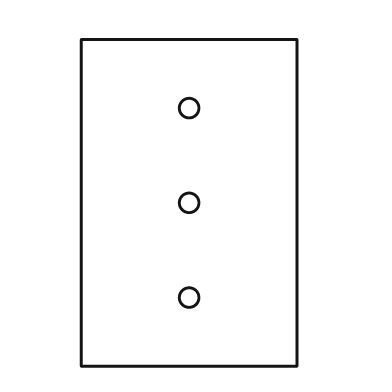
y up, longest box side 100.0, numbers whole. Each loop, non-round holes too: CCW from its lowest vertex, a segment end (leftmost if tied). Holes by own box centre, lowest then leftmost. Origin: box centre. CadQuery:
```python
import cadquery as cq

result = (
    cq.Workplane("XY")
    .moveTo(-33.0, -50.0)
    .lineTo(33.0, -50.0)
    .lineTo(33.0, 50.0)
    .lineTo(-33.0, 50.0)
    .close()
    .moveTo(0.0, -29.0)
    .circle(3.0)
    .moveTo(0.0, 0.0)
    .circle(3.0)
    .moveTo(0.0, 29.0)
    .circle(3.0)
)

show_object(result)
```